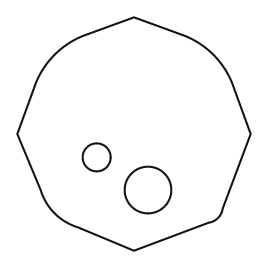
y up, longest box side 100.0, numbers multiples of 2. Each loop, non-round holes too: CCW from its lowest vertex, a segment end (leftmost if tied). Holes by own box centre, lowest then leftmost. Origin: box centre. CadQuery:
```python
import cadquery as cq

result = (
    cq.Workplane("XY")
    .moveTo(0.0, -50.0)
    .lineTo(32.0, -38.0)
    .threePointArc((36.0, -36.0), (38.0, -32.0))
    .lineTo(50.0, 0.0)
    .lineTo(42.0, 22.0)
    .threePointArc((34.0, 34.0), (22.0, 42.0))
    .lineTo(0.0, 50.0)
    .lineTo(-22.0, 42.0)
    .threePointArc((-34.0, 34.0), (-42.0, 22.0))
    .lineTo(-50.0, 0.0)
    .lineTo(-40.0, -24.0)
    .threePointArc((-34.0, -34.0), (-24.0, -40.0))
    .close()
    .moveTo(6.0, -24.0)
    .circle(10.0)
    .moveTo(-16.0, -10.0)
    .circle(6.0)
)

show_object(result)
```